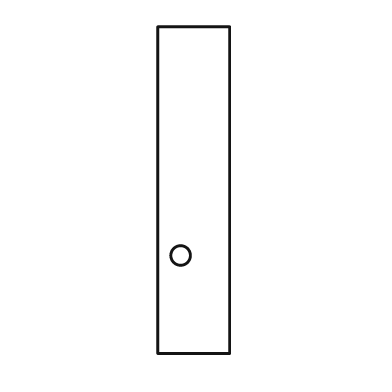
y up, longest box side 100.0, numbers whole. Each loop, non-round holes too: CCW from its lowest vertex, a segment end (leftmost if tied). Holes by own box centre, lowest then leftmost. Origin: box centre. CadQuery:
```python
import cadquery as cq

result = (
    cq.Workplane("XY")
    .moveTo(-11.0, -50.0)
    .lineTo(11.0, -50.0)
    .lineTo(11.0, 50.0)
    .lineTo(-11.0, 50.0)
    .close()
    .moveTo(-4.0, -20.0)
    .circle(3.0)
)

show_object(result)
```